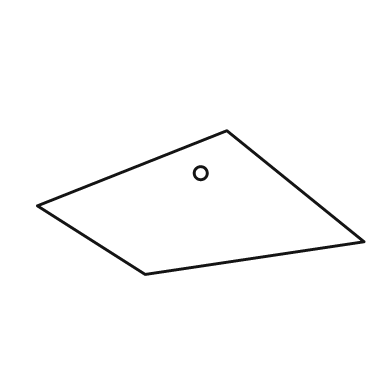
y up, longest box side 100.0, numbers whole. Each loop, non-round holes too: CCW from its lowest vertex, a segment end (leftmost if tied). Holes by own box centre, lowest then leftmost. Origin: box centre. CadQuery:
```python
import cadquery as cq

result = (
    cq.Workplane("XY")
    .moveTo(-17.0, -22.0)
    .lineTo(50.0, -12.0)
    .lineTo(8.0, 22.0)
    .lineTo(-50.0, -1.0)
    .close()
    .moveTo(0.0, 9.0)
    .circle(2.0)
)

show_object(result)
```